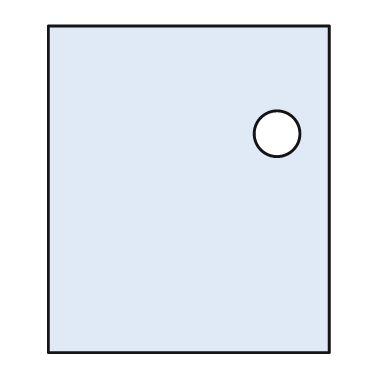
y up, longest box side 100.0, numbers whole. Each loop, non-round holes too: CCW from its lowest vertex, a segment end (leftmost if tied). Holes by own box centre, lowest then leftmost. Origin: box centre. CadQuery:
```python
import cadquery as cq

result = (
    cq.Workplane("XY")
    .moveTo(-43.0, -50.0)
    .lineTo(43.0, -50.0)
    .lineTo(43.0, 50.0)
    .lineTo(-43.0, 50.0)
    .close()
    .moveTo(27.0, 17.0)
    .circle(7.0)
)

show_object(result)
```